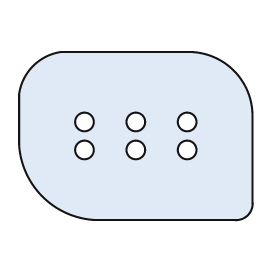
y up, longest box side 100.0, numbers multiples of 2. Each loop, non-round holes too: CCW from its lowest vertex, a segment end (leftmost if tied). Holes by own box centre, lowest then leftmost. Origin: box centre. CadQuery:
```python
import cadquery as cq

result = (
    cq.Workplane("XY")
    .moveTo(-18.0, -36.0)
    .lineTo(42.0, -36.0)
    .threePointArc((48.0, -34.0), (50.0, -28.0))
    .lineTo(50.0, 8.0)
    .threePointArc((42.0, 28.0), (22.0, 36.0))
    .lineTo(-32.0, 36.0)
    .threePointArc((-44.0, 30.0), (-50.0, 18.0))
    .lineTo(-50.0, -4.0)
    .threePointArc((-40.0, -26.0), (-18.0, -36.0))
    .close()
    .moveTo(-22.0, -6.0)
    .circle(4.0)
    .moveTo(0.0, -6.0)
    .circle(4.0)
    .moveTo(22.0, -6.0)
    .circle(4.0)
    .moveTo(-22.0, 6.0)
    .circle(4.0)
    .moveTo(0.0, 6.0)
    .circle(4.0)
    .moveTo(22.0, 6.0)
    .circle(4.0)
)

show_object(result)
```